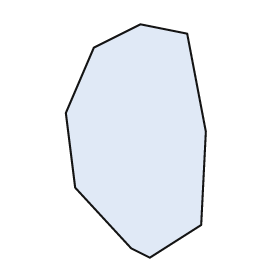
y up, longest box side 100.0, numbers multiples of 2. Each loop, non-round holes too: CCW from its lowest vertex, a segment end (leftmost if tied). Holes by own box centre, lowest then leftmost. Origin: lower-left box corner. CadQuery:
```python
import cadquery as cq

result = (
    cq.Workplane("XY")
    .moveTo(36.0, 0.0)
    .lineTo(58.0, 14.0)
    .lineTo(60.0, 54.0)
    .lineTo(52.0, 96.0)
    .lineTo(32.0, 100.0)
    .lineTo(12.0, 90.0)
    .lineTo(0.0, 62.0)
    .lineTo(4.0, 30.0)
    .lineTo(28.0, 4.0)
    .close()
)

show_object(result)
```